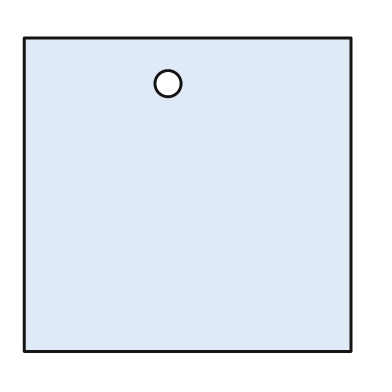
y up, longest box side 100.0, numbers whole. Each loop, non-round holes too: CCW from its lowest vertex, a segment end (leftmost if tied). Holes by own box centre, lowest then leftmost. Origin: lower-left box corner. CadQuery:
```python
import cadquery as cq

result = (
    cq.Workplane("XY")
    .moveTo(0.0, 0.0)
    .lineTo(100.0, 0.0)
    .lineTo(100.0, 96.0)
    .lineTo(0.0, 96.0)
    .close()
    .moveTo(44.0, 82.0)
    .circle(4.0)
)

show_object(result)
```